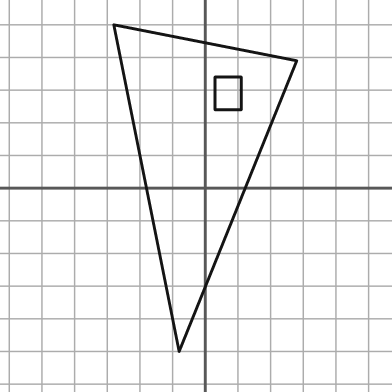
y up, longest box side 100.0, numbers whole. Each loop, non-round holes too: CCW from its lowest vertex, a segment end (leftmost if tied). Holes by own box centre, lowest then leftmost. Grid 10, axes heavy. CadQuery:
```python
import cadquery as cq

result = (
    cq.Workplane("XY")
    .moveTo(-8.0, -50.0)
    .lineTo(28.0, 39.0)
    .lineTo(-28.0, 50.0)
    .close()
    .moveTo(3.0, 24.0)
    .lineTo(11.0, 24.0)
    .lineTo(11.0, 34.0)
    .lineTo(3.0, 34.0)
    .close()
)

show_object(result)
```